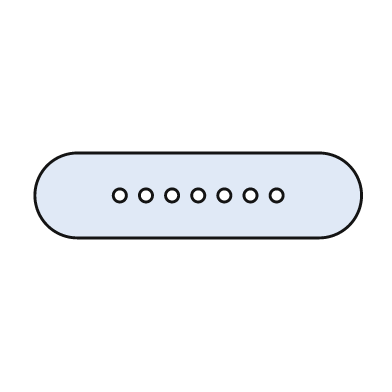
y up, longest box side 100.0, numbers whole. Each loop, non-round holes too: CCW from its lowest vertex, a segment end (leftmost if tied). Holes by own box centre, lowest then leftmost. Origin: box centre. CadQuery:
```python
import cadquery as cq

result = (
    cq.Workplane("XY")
    .moveTo(-37.0, -13.0)
    .lineTo(37.0, -13.0)
    .threePointArc((50.0, 0.0), (37.0, 13.0))
    .lineTo(-37.0, 13.0)
    .threePointArc((-50.0, 0.0), (-37.0, -13.0))
    .close()
    .moveTo(-24.0, 0.0)
    .circle(2.0)
    .moveTo(-16.0, 0.0)
    .circle(2.0)
    .moveTo(-8.0, 0.0)
    .circle(2.0)
    .moveTo(0.0, 0.0)
    .circle(2.0)
    .moveTo(8.0, 0.0)
    .circle(2.0)
    .moveTo(16.0, 0.0)
    .circle(2.0)
    .moveTo(24.0, 0.0)
    .circle(2.0)
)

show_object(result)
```